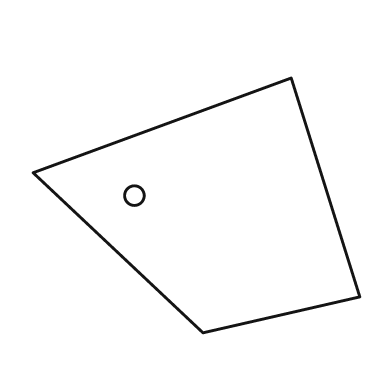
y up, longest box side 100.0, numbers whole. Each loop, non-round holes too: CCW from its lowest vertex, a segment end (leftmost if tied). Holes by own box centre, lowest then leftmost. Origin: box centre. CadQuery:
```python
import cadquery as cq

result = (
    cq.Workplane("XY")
    .moveTo(2.0, -39.0)
    .lineTo(50.0, -28.0)
    .lineTo(29.0, 39.0)
    .lineTo(-50.0, 10.0)
    .close()
    .moveTo(-19.0, 3.0)
    .circle(3.0)
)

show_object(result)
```